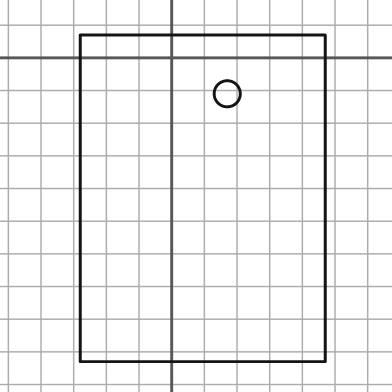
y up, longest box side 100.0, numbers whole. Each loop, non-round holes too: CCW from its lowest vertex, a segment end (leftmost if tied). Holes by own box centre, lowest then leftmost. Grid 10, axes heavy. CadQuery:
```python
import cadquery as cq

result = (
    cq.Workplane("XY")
    .moveTo(-28.0, -93.0)
    .lineTo(47.0, -93.0)
    .lineTo(47.0, 7.0)
    .lineTo(-28.0, 7.0)
    .close()
    .moveTo(17.0, -11.0)
    .circle(4.0)
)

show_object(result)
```